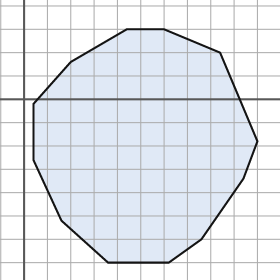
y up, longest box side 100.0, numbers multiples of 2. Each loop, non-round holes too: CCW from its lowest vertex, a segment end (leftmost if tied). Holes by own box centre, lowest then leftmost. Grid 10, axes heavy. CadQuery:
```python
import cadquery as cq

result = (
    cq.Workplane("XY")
    .moveTo(36.0, -70.0)
    .lineTo(62.0, -70.0)
    .lineTo(76.0, -60.0)
    .lineTo(94.0, -34.0)
    .lineTo(100.0, -18.0)
    .lineTo(84.0, 20.0)
    .lineTo(60.0, 30.0)
    .lineTo(44.0, 30.0)
    .lineTo(20.0, 16.0)
    .lineTo(4.0, -2.0)
    .lineTo(4.0, -26.0)
    .lineTo(16.0, -52.0)
    .close()
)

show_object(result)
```